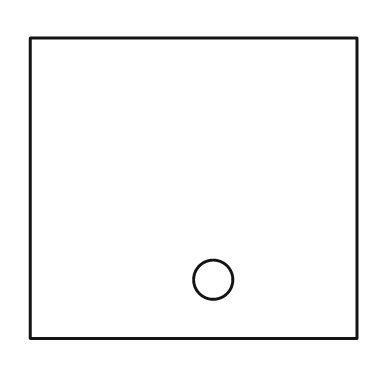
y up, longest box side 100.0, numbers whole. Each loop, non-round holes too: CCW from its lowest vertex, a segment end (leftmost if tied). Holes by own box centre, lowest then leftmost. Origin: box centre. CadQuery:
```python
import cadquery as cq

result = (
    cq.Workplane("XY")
    .moveTo(-50.0, -46.0)
    .lineTo(50.0, -46.0)
    .lineTo(50.0, 46.0)
    .lineTo(-50.0, 46.0)
    .close()
    .moveTo(6.0, -28.0)
    .circle(6.0)
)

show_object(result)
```